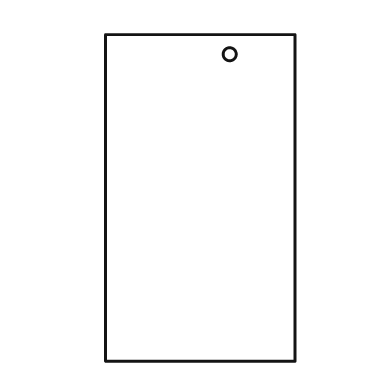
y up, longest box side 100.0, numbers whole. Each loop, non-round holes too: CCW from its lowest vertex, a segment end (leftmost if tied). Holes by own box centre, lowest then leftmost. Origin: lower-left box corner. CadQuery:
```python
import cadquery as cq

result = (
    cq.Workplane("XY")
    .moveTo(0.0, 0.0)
    .lineTo(58.0, 0.0)
    .lineTo(58.0, 100.0)
    .lineTo(0.0, 100.0)
    .close()
    .moveTo(38.0, 94.0)
    .circle(2.0)
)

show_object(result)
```